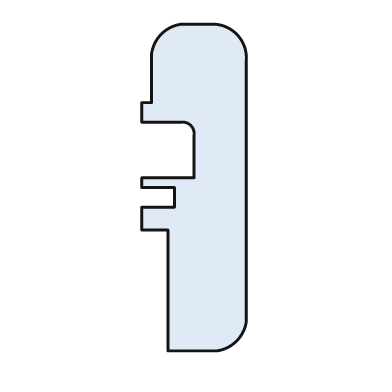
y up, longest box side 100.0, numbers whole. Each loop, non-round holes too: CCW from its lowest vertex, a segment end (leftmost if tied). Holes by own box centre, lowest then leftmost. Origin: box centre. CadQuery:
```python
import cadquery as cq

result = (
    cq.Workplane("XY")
    .moveTo(-8.0, -50.0)
    .lineTo(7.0, -50.0)
    .threePointArc((13.0, -47.0), (16.0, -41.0))
    .lineTo(16.0, 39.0)
    .threePointArc((13.0, 47.0), (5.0, 50.0))
    .lineTo(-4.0, 50.0)
    .threePointArc((-10.0, 47.0), (-13.0, 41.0))
    .lineTo(-13.0, 26.0)
    .lineTo(-16.0, 26.0)
    .lineTo(-16.0, 20.0)
    .lineTo(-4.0, 20.0)
    .threePointArc((-1.0, 19.0), (0.0, 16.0))
    .lineTo(0.0, 3.0)
    .lineTo(-16.0, 3.0)
    .lineTo(-16.0, 0.0)
    .lineTo(-6.0, 0.0)
    .lineTo(-6.0, -6.0)
    .lineTo(-16.0, -6.0)
    .lineTo(-16.0, -13.0)
    .lineTo(-8.0, -13.0)
    .close()
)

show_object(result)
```